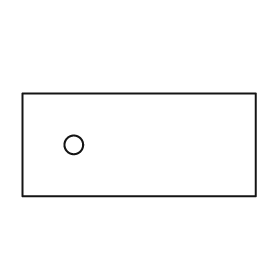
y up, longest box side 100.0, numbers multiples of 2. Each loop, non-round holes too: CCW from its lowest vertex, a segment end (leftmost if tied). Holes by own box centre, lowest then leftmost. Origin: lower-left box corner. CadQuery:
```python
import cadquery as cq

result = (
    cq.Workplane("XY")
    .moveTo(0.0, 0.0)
    .lineTo(100.0, 0.0)
    .lineTo(100.0, 44.0)
    .lineTo(0.0, 44.0)
    .close()
    .moveTo(22.0, 22.0)
    .circle(4.0)
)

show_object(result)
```